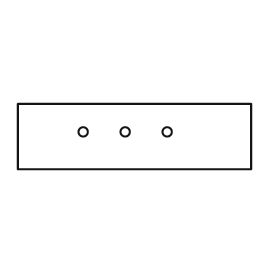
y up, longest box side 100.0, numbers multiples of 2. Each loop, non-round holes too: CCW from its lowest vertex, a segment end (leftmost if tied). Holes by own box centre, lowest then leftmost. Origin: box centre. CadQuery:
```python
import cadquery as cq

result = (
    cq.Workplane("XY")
    .moveTo(-50.0, -14.0)
    .lineTo(50.0, -14.0)
    .lineTo(50.0, 14.0)
    .lineTo(-50.0, 14.0)
    .close()
    .moveTo(-22.0, 2.0)
    .circle(2.0)
    .moveTo(-4.0, 2.0)
    .circle(2.0)
    .moveTo(14.0, 2.0)
    .circle(2.0)
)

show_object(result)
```